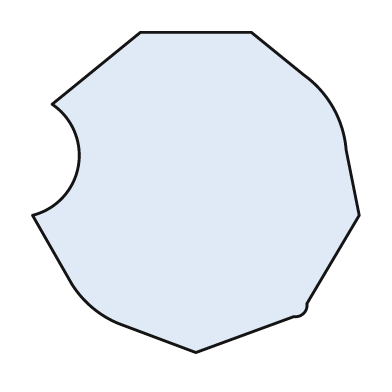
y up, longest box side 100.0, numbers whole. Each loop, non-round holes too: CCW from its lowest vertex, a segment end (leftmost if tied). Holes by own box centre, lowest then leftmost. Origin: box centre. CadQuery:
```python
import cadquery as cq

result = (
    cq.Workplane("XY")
    .moveTo(0.0, -49.0)
    .lineTo(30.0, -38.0)
    .threePointArc((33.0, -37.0), (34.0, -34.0))
    .lineTo(50.0, -7.0)
    .lineTo(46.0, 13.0)
    .threePointArc((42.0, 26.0), (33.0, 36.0))
    .lineTo(17.0, 49.0)
    .lineTo(-17.0, 49.0)
    .lineTo(-44.0, 27.0)
    .threePointArc((-36.0, 8.0), (-50.0, -7.0))
    .lineTo(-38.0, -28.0)
    .threePointArc((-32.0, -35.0), (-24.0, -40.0))
    .close()
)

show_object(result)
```